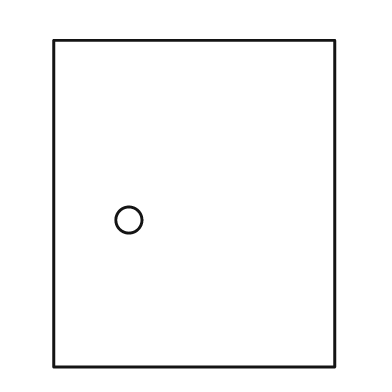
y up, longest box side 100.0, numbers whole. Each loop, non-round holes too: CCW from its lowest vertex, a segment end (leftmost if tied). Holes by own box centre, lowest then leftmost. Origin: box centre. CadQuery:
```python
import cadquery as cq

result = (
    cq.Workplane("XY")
    .moveTo(-43.0, -50.0)
    .lineTo(43.0, -50.0)
    .lineTo(43.0, 50.0)
    .lineTo(-43.0, 50.0)
    .close()
    .moveTo(-20.0, -5.0)
    .circle(4.0)
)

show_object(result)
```